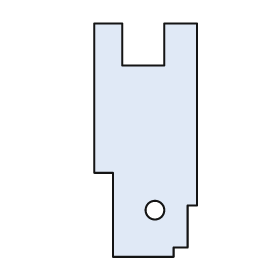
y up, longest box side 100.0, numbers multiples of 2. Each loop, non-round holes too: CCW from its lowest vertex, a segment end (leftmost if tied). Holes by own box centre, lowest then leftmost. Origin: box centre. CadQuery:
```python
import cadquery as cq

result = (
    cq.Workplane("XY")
    .moveTo(-14.0, -50.0)
    .lineTo(12.0, -50.0)
    .lineTo(12.0, -46.0)
    .lineTo(18.0, -46.0)
    .lineTo(18.0, -28.0)
    .lineTo(22.0, -28.0)
    .lineTo(22.0, 50.0)
    .lineTo(8.0, 50.0)
    .lineTo(8.0, 32.0)
    .lineTo(-10.0, 32.0)
    .lineTo(-10.0, 50.0)
    .lineTo(-22.0, 50.0)
    .lineTo(-22.0, -14.0)
    .lineTo(-14.0, -14.0)
    .close()
    .moveTo(4.0, -30.0)
    .circle(4.0)
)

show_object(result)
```